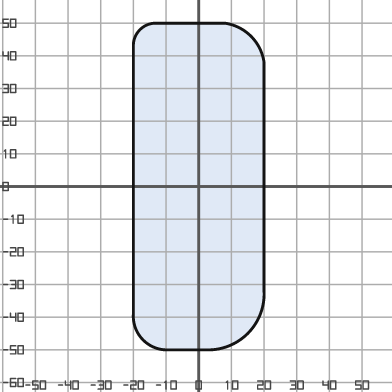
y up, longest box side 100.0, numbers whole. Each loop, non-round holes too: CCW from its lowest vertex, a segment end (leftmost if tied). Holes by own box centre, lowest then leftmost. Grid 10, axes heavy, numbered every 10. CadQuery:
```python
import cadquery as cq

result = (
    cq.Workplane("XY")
    .moveTo(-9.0, -50.0)
    .lineTo(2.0, -50.0)
    .threePointArc((15.0, -45.0), (20.0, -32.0))
    .lineTo(20.0, 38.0)
    .threePointArc((16.0, 46.0), (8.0, 50.0))
    .lineTo(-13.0, 50.0)
    .threePointArc((-18.0, 48.0), (-20.0, 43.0))
    .lineTo(-20.0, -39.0)
    .threePointArc((-17.0, -47.0), (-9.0, -50.0))
    .close()
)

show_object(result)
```